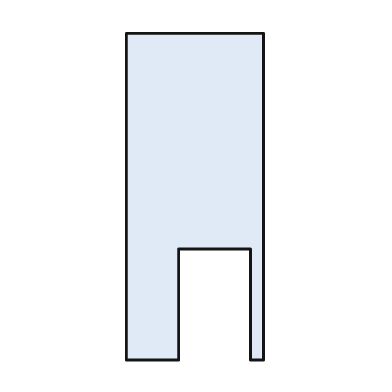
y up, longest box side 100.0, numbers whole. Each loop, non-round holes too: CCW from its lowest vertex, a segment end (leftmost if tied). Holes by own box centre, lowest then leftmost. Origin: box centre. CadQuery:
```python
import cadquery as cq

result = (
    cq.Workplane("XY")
    .moveTo(-21.0, -50.0)
    .lineTo(-5.0, -50.0)
    .lineTo(-5.0, -16.0)
    .lineTo(17.0, -16.0)
    .lineTo(17.0, -50.0)
    .lineTo(21.0, -50.0)
    .lineTo(21.0, 50.0)
    .lineTo(-21.0, 50.0)
    .close()
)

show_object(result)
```